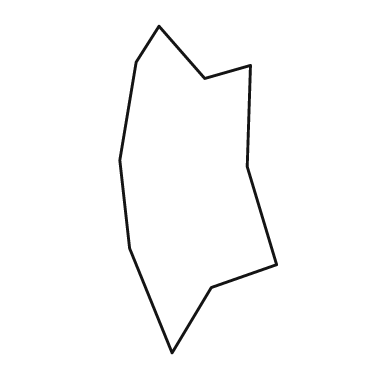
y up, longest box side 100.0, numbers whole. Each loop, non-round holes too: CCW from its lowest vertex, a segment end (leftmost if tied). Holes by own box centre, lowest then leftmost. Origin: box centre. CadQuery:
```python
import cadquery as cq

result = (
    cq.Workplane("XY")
    .moveTo(-8.0, -50.0)
    .lineTo(4.0, -30.0)
    .lineTo(24.0, -23.0)
    .lineTo(15.0, 7.0)
    .lineTo(16.0, 38.0)
    .lineTo(2.0, 34.0)
    .lineTo(-12.0, 50.0)
    .lineTo(-19.0, 39.0)
    .lineTo(-24.0, 9.0)
    .lineTo(-21.0, -18.0)
    .close()
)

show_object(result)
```